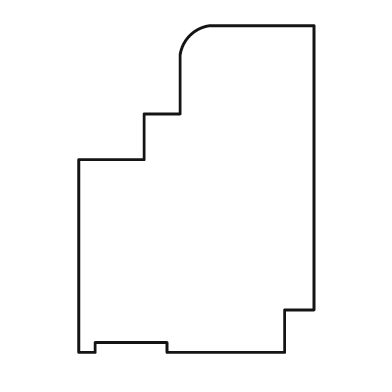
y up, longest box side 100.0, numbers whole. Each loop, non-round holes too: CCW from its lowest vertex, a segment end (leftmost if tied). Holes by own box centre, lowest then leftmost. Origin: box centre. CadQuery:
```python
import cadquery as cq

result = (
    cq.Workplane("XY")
    .moveTo(-36.0, -50.0)
    .lineTo(-31.0, -50.0)
    .lineTo(-31.0, -47.0)
    .lineTo(-9.0, -47.0)
    .lineTo(-9.0, -50.0)
    .lineTo(27.0, -50.0)
    .lineTo(27.0, -37.0)
    .lineTo(36.0, -37.0)
    .lineTo(36.0, 50.0)
    .lineTo(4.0, 50.0)
    .threePointArc((-2.0, 47.0), (-5.0, 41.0))
    .lineTo(-5.0, 23.0)
    .lineTo(-16.0, 23.0)
    .lineTo(-16.0, 9.0)
    .lineTo(-36.0, 9.0)
    .close()
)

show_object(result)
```